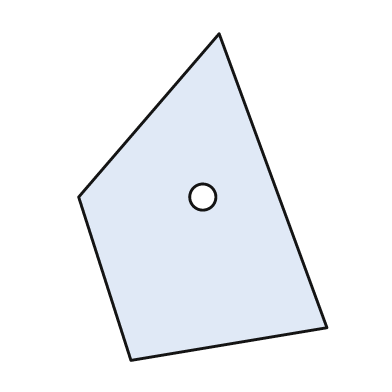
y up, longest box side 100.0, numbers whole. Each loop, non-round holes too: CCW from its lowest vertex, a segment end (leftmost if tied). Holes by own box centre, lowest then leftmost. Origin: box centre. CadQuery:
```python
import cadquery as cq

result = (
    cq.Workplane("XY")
    .moveTo(-22.0, -50.0)
    .lineTo(38.0, -40.0)
    .lineTo(5.0, 50.0)
    .lineTo(-38.0, 0.0)
    .close()
    .moveTo(0.0, 0.0)
    .circle(4.0)
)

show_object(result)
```